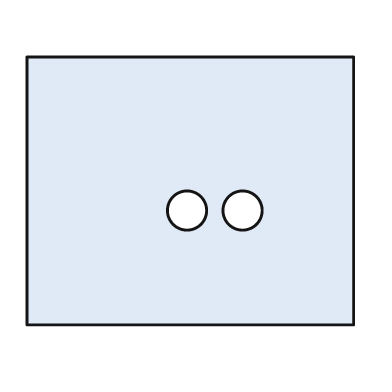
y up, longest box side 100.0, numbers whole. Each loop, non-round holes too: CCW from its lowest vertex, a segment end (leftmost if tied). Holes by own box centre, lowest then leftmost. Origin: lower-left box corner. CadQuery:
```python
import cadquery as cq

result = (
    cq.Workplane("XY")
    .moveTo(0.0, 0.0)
    .lineTo(100.0, 0.0)
    .lineTo(100.0, 82.0)
    .lineTo(0.0, 82.0)
    .close()
    .moveTo(49.0, 35.0)
    .circle(6.0)
    .moveTo(66.0, 35.0)
    .circle(6.0)
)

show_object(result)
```